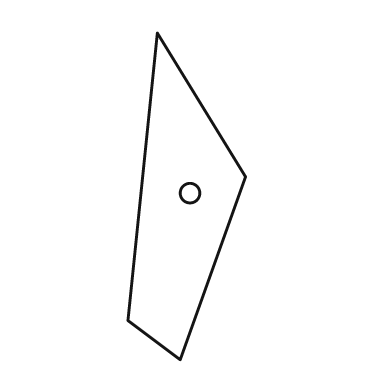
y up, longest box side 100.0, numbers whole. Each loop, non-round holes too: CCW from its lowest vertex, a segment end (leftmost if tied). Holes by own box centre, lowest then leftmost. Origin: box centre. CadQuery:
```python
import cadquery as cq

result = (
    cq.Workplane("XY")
    .moveTo(-2.0, -50.0)
    .lineTo(18.0, 6.0)
    .lineTo(-9.0, 50.0)
    .lineTo(-18.0, -38.0)
    .close()
    .moveTo(1.0, 1.0)
    .circle(3.0)
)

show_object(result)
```